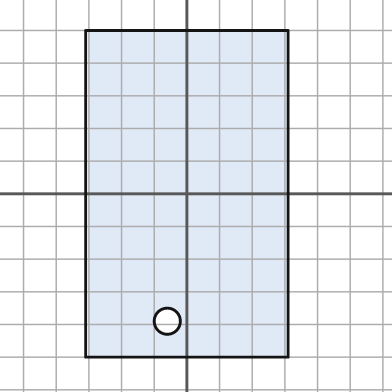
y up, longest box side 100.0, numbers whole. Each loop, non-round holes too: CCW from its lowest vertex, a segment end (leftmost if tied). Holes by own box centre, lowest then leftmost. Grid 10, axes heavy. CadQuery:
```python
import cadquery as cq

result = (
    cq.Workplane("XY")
    .moveTo(-31.0, -50.0)
    .lineTo(31.0, -50.0)
    .lineTo(31.0, 50.0)
    .lineTo(-31.0, 50.0)
    .close()
    .moveTo(-6.0, -39.0)
    .circle(4.0)
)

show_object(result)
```